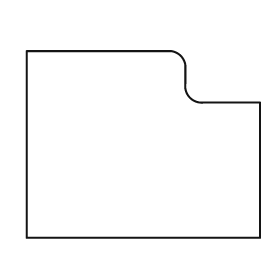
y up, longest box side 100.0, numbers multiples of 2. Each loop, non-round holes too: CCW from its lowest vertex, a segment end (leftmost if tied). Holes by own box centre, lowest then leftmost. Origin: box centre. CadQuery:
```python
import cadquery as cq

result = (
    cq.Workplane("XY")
    .moveTo(-50.0, -40.0)
    .lineTo(50.0, -40.0)
    .lineTo(50.0, 18.0)
    .lineTo(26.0, 18.0)
    .threePointArc((20.0, 20.0), (18.0, 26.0))
    .lineTo(18.0, 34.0)
    .threePointArc((16.0, 38.0), (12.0, 40.0))
    .lineTo(-50.0, 40.0)
    .close()
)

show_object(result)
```